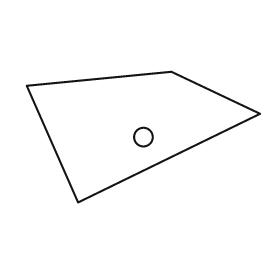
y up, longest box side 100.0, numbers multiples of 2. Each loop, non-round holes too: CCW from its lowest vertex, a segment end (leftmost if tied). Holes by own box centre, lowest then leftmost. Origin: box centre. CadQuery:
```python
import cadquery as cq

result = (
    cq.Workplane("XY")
    .moveTo(-28.0, -28.0)
    .lineTo(50.0, 10.0)
    .lineTo(12.0, 28.0)
    .lineTo(-50.0, 22.0)
    .close()
    .moveTo(0.0, 0.0)
    .circle(4.0)
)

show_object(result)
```